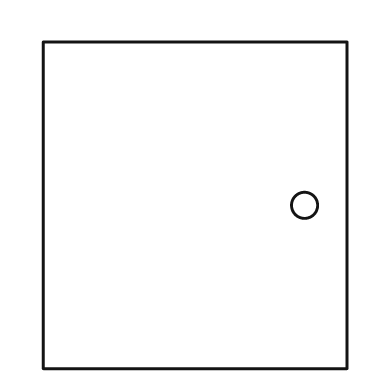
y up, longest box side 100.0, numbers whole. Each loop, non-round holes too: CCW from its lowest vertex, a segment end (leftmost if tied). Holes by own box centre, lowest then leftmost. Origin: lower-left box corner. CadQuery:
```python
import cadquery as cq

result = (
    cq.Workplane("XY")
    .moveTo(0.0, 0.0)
    .lineTo(93.0, 0.0)
    .lineTo(93.0, 100.0)
    .lineTo(0.0, 100.0)
    .close()
    .moveTo(80.0, 50.0)
    .circle(4.0)
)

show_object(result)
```